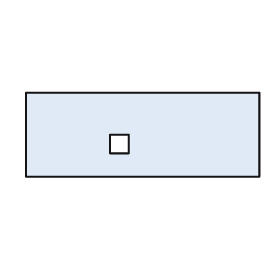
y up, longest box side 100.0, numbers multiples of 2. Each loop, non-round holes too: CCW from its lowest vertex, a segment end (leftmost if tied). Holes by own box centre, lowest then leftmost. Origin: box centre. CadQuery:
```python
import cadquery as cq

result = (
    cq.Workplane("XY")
    .moveTo(-50.0, -18.0)
    .lineTo(50.0, -18.0)
    .lineTo(50.0, 18.0)
    .lineTo(-50.0, 18.0)
    .close()
    .moveTo(-14.0, -8.0)
    .lineTo(-6.0, -8.0)
    .lineTo(-6.0, 0.0)
    .lineTo(-14.0, 0.0)
    .close()
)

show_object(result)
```